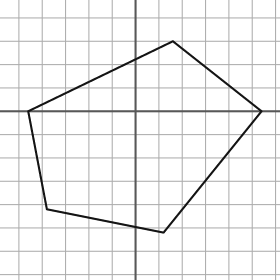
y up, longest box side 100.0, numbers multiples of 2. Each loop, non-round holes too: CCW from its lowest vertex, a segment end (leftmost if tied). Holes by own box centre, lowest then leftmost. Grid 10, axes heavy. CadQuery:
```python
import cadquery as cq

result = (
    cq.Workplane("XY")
    .moveTo(12.0, -52.0)
    .lineTo(54.0, 0.0)
    .lineTo(16.0, 30.0)
    .lineTo(-46.0, 0.0)
    .lineTo(-38.0, -42.0)
    .close()
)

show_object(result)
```